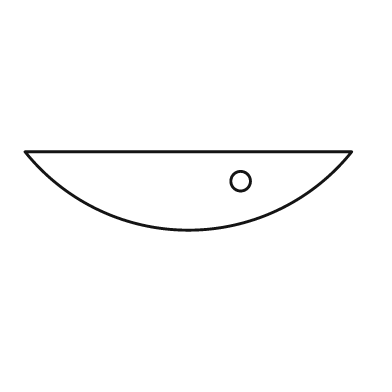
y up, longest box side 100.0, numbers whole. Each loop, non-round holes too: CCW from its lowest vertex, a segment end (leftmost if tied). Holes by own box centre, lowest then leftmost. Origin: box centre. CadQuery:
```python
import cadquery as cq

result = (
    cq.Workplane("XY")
    .moveTo(-50.0, 12.0)
    .threePointArc((0.0, -12.0), (50.0, 12.0))
    .close()
    .moveTo(16.0, 3.0)
    .circle(3.0)
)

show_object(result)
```